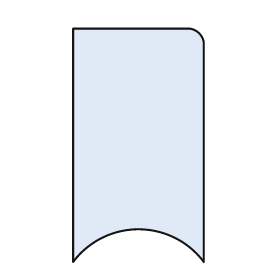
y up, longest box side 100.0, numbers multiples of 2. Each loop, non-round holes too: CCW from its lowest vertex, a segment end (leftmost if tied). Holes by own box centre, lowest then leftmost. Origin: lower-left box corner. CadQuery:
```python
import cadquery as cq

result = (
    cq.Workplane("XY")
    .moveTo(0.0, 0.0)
    .threePointArc((28.0, 14.0), (56.0, 0.0))
    .lineTo(56.0, 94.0)
    .threePointArc((54.0, 98.0), (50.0, 100.0))
    .lineTo(0.0, 100.0)
    .close()
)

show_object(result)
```